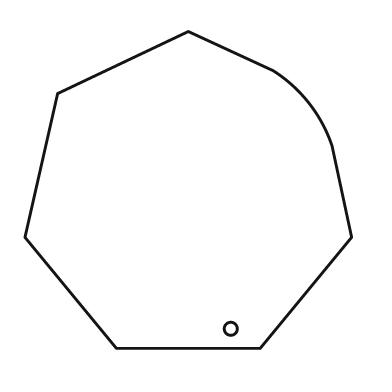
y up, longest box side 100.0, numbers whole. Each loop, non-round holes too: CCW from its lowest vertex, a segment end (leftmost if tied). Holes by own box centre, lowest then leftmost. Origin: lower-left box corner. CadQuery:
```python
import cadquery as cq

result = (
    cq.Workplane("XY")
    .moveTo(28.0, 0.0)
    .lineTo(72.0, 0.0)
    .lineTo(100.0, 34.0)
    .lineTo(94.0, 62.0)
    .threePointArc((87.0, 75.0), (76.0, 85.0))
    .lineTo(50.0, 97.0)
    .lineTo(10.0, 78.0)
    .lineTo(0.0, 34.0)
    .close()
    .moveTo(63.0, 6.0)
    .circle(2.0)
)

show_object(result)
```